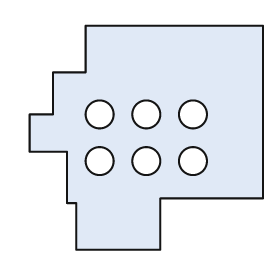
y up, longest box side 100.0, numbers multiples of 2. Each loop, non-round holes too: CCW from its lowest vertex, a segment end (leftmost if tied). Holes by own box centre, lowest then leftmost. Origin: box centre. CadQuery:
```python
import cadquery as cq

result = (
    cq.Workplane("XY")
    .moveTo(-30.0, -48.0)
    .lineTo(6.0, -48.0)
    .lineTo(6.0, -26.0)
    .lineTo(50.0, -26.0)
    .lineTo(50.0, 48.0)
    .lineTo(-26.0, 48.0)
    .lineTo(-26.0, 28.0)
    .lineTo(-40.0, 28.0)
    .lineTo(-40.0, 10.0)
    .lineTo(-50.0, 10.0)
    .lineTo(-50.0, -6.0)
    .lineTo(-34.0, -6.0)
    .lineTo(-34.0, -28.0)
    .lineTo(-30.0, -28.0)
    .close()
    .moveTo(-20.0, -10.0)
    .circle(6.0)
    .moveTo(0.0, -10.0)
    .circle(6.0)
    .moveTo(20.0, -10.0)
    .circle(6.0)
    .moveTo(-20.0, 10.0)
    .circle(6.0)
    .moveTo(0.0, 10.0)
    .circle(6.0)
    .moveTo(20.0, 10.0)
    .circle(6.0)
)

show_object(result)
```